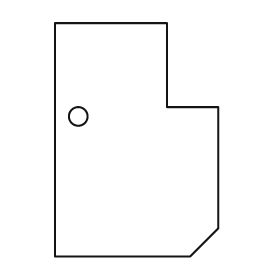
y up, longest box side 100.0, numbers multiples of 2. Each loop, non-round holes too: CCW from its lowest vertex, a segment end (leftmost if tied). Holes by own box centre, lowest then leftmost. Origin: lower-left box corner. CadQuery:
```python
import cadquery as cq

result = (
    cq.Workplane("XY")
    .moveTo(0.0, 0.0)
    .lineTo(58.0, 0.0)
    .lineTo(70.0, 12.0)
    .lineTo(70.0, 64.0)
    .lineTo(48.0, 64.0)
    .lineTo(48.0, 100.0)
    .lineTo(0.0, 100.0)
    .close()
    .moveTo(10.0, 60.0)
    .circle(4.0)
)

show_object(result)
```